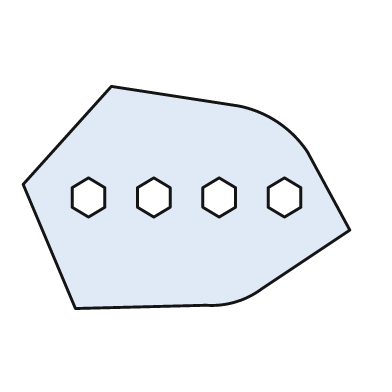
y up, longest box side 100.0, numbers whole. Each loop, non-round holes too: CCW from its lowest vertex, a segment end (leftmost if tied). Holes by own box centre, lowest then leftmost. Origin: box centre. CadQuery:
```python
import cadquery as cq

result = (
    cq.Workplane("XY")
    .moveTo(-34.0, -34.0)
    .lineTo(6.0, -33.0)
    .threePointArc((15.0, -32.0), (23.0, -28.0))
    .lineTo(50.0, -10.0)
    .lineTo(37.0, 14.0)
    .threePointArc((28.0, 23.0), (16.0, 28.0))
    .lineTo(-23.0, 34.0)
    .lineTo(-50.0, 4.0)
    .close()
    .moveTo(-30.0, -6.0)
    .lineTo(-25.0, -3.0)
    .lineTo(-25.0, 3.0)
    .lineTo(-30.0, 6.0)
    .lineTo(-35.0, 3.0)
    .lineTo(-35.0, -3.0)
    .close()
    .moveTo(-10.0, -6.0)
    .lineTo(-5.0, -3.0)
    .lineTo(-5.0, 3.0)
    .lineTo(-10.0, 6.0)
    .lineTo(-15.0, 3.0)
    .lineTo(-15.0, -3.0)
    .close()
    .moveTo(10.0, -6.0)
    .lineTo(15.0, -3.0)
    .lineTo(15.0, 3.0)
    .lineTo(10.0, 6.0)
    .lineTo(5.0, 3.0)
    .lineTo(5.0, -3.0)
    .close()
    .moveTo(30.0, -6.0)
    .lineTo(35.0, -3.0)
    .lineTo(35.0, 3.0)
    .lineTo(30.0, 6.0)
    .lineTo(25.0, 3.0)
    .lineTo(25.0, -3.0)
    .close()
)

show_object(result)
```